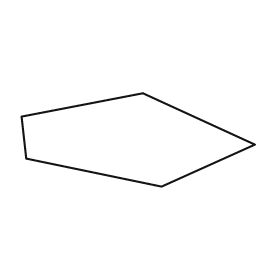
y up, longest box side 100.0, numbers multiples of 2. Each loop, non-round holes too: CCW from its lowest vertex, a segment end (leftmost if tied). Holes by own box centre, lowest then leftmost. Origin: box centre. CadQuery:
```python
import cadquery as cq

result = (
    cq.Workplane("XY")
    .moveTo(10.0, -20.0)
    .lineTo(50.0, -2.0)
    .lineTo(2.0, 20.0)
    .lineTo(-50.0, 10.0)
    .lineTo(-48.0, -8.0)
    .close()
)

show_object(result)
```